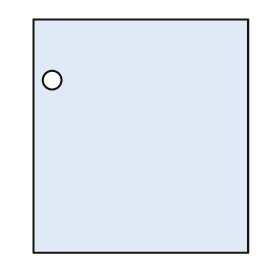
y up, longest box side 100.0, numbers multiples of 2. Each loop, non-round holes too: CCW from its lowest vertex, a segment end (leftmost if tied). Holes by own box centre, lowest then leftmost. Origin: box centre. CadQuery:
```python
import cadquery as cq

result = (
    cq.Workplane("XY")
    .moveTo(-46.0, -50.0)
    .lineTo(46.0, -50.0)
    .lineTo(46.0, 50.0)
    .lineTo(-46.0, 50.0)
    .close()
    .moveTo(-38.0, 24.0)
    .circle(4.0)
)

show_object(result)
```